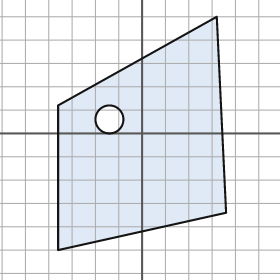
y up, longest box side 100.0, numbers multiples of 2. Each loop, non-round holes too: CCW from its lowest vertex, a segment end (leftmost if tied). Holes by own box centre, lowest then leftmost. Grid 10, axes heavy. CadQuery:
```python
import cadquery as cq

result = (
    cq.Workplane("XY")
    .moveTo(-36.0, -50.0)
    .lineTo(36.0, -34.0)
    .lineTo(32.0, 50.0)
    .lineTo(-36.0, 12.0)
    .close()
    .moveTo(-14.0, 6.0)
    .circle(6.0)
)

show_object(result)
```